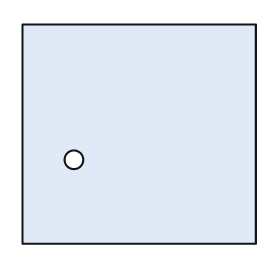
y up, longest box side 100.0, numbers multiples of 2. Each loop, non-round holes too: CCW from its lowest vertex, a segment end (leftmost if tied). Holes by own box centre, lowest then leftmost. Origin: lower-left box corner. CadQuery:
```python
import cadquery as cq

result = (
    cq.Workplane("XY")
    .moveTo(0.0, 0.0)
    .lineTo(100.0, 0.0)
    .lineTo(100.0, 94.0)
    .lineTo(0.0, 94.0)
    .close()
    .moveTo(22.0, 36.0)
    .circle(4.0)
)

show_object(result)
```